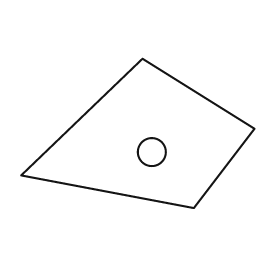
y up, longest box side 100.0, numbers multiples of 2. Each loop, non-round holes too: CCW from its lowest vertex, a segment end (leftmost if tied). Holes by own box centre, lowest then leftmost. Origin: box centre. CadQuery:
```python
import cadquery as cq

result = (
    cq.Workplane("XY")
    .moveTo(24.0, -32.0)
    .lineTo(50.0, 2.0)
    .lineTo(2.0, 32.0)
    .lineTo(-50.0, -18.0)
    .close()
    .moveTo(6.0, -8.0)
    .circle(6.0)
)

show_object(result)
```